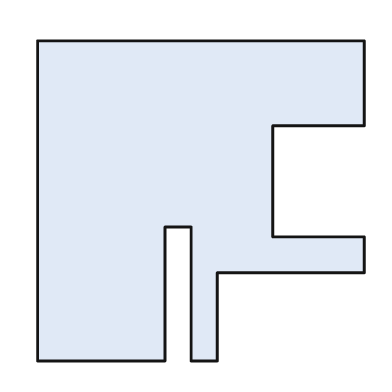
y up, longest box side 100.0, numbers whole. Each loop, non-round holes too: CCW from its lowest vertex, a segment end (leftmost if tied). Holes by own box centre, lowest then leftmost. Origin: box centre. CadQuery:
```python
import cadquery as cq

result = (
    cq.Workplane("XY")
    .moveTo(-50.0, -49.0)
    .lineTo(-11.0, -49.0)
    .lineTo(-11.0, -8.0)
    .lineTo(-3.0, -8.0)
    .lineTo(-3.0, -49.0)
    .lineTo(5.0, -49.0)
    .lineTo(5.0, -22.0)
    .lineTo(50.0, -22.0)
    .lineTo(50.0, -11.0)
    .lineTo(22.0, -11.0)
    .lineTo(22.0, 23.0)
    .lineTo(50.0, 23.0)
    .lineTo(50.0, 49.0)
    .lineTo(-50.0, 49.0)
    .close()
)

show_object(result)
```